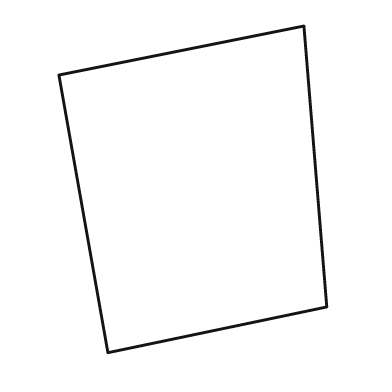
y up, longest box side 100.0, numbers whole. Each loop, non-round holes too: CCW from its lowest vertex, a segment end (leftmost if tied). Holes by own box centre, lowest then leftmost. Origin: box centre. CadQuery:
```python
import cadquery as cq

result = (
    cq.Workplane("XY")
    .moveTo(-26.0, -50.0)
    .lineTo(41.0, -36.0)
    .lineTo(34.0, 50.0)
    .lineTo(-41.0, 35.0)
    .close()
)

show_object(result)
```